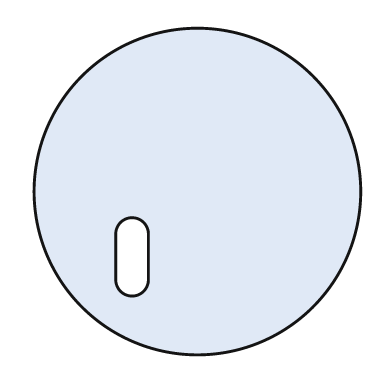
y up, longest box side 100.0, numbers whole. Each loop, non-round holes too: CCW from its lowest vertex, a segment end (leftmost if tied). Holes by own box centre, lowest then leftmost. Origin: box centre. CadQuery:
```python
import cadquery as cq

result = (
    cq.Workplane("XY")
    .moveTo(0.0, 0.0)
    .circle(50.0)
    .moveTo(-25.0, -27.0)
    .threePointArc((-20.0, -32.0), (-15.0, -27.0))
    .lineTo(-15.0, -13.0)
    .threePointArc((-20.0, -8.0), (-25.0, -13.0))
    .close()
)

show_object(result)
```